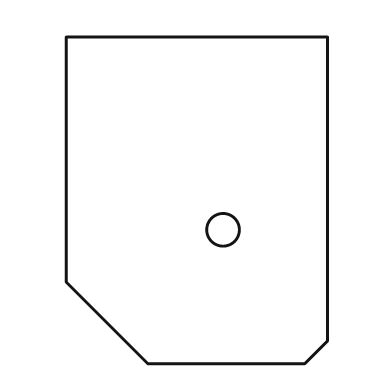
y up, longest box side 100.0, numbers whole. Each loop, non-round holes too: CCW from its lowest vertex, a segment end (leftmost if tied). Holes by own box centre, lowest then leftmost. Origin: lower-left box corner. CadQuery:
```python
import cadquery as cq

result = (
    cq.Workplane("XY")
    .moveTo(25.0, 0.0)
    .lineTo(73.0, 0.0)
    .lineTo(80.0, 7.0)
    .lineTo(80.0, 100.0)
    .lineTo(0.0, 100.0)
    .lineTo(0.0, 25.0)
    .close()
    .moveTo(48.0, 41.0)
    .circle(5.0)
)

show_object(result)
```